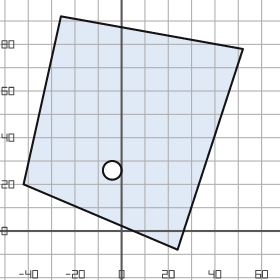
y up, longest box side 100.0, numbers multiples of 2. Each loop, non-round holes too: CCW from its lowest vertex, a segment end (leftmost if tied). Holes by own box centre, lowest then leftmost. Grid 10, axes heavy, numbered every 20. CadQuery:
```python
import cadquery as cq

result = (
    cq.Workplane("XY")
    .moveTo(24.0, -8.0)
    .lineTo(52.0, 78.0)
    .lineTo(-26.0, 92.0)
    .lineTo(-42.0, 20.0)
    .close()
    .moveTo(-4.0, 26.0)
    .circle(4.0)
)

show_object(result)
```